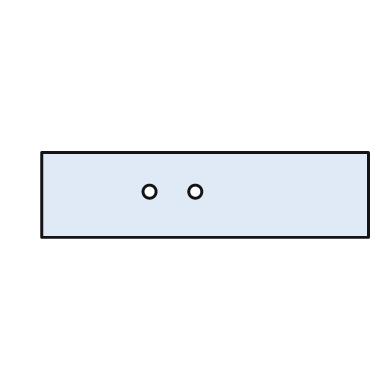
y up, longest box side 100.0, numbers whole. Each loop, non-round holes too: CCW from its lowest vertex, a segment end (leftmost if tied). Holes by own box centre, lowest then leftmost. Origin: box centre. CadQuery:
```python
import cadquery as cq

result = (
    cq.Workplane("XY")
    .moveTo(-50.0, -13.0)
    .lineTo(50.0, -13.0)
    .lineTo(50.0, 13.0)
    .lineTo(-50.0, 13.0)
    .close()
    .moveTo(-17.0, 1.0)
    .circle(2.0)
    .moveTo(-3.0, 1.0)
    .circle(2.0)
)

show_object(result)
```